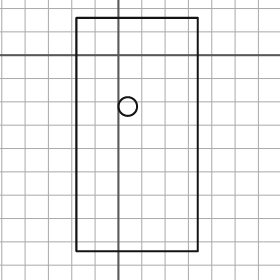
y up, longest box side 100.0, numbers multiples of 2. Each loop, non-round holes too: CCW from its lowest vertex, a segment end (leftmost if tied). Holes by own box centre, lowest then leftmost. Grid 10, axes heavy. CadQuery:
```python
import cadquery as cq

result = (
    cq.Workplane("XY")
    .moveTo(-18.0, -84.0)
    .lineTo(34.0, -84.0)
    .lineTo(34.0, 16.0)
    .lineTo(-18.0, 16.0)
    .close()
    .moveTo(4.0, -22.0)
    .circle(4.0)
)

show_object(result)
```